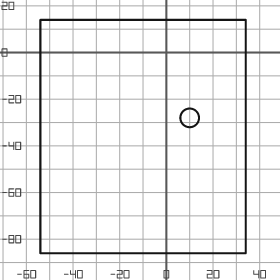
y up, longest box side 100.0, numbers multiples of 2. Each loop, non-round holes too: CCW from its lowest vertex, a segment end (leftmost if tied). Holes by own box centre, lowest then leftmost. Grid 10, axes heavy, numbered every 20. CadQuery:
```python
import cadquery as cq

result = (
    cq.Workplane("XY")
    .moveTo(-54.0, -86.0)
    .lineTo(34.0, -86.0)
    .lineTo(34.0, 14.0)
    .lineTo(-54.0, 14.0)
    .close()
    .moveTo(10.0, -28.0)
    .circle(4.0)
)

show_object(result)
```